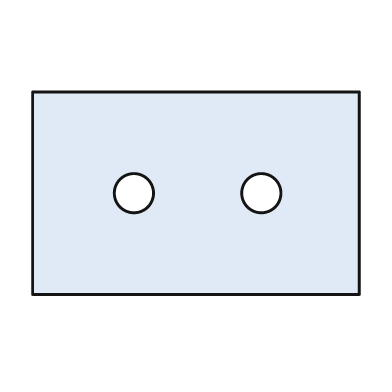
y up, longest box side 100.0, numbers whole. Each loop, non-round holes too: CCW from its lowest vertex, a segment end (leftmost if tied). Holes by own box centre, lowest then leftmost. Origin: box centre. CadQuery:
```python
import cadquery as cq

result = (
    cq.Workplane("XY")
    .moveTo(-50.0, -31.0)
    .lineTo(50.0, -31.0)
    .lineTo(50.0, 31.0)
    .lineTo(-50.0, 31.0)
    .close()
    .moveTo(-19.0, 0.0)
    .circle(6.0)
    .moveTo(20.0, 0.0)
    .circle(6.0)
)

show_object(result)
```